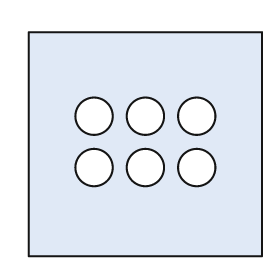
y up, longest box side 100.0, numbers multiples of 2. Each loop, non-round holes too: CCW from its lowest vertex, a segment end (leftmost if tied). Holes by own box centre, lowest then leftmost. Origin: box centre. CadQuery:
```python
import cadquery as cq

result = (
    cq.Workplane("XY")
    .moveTo(-50.0, -48.0)
    .lineTo(50.0, -48.0)
    .lineTo(50.0, 48.0)
    .lineTo(-50.0, 48.0)
    .close()
    .moveTo(-22.0, -10.0)
    .circle(8.0)
    .moveTo(0.0, -10.0)
    .circle(8.0)
    .moveTo(22.0, -10.0)
    .circle(8.0)
    .moveTo(-22.0, 12.0)
    .circle(8.0)
    .moveTo(0.0, 12.0)
    .circle(8.0)
    .moveTo(22.0, 12.0)
    .circle(8.0)
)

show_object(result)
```